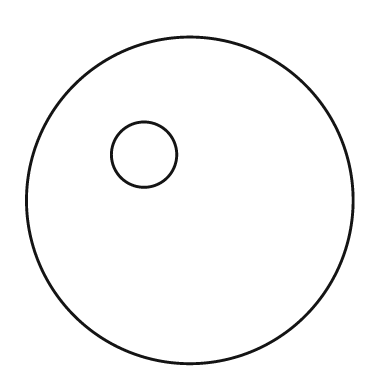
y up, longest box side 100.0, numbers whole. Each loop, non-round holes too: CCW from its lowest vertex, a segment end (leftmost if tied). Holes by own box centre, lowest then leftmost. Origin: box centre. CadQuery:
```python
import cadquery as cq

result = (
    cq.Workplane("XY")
    .moveTo(0.0, 0.0)
    .circle(50.0)
    .moveTo(-14.0, 14.0)
    .circle(10.0)
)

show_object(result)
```